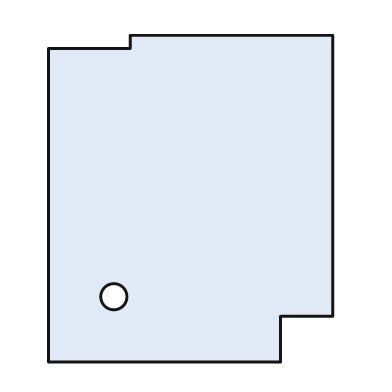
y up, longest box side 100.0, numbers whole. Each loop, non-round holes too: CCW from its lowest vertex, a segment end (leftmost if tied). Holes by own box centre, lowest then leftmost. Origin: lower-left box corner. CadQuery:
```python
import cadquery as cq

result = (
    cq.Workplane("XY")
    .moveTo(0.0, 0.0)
    .lineTo(71.0, 0.0)
    .lineTo(71.0, 14.0)
    .lineTo(87.0, 14.0)
    .lineTo(87.0, 100.0)
    .lineTo(25.0, 100.0)
    .lineTo(25.0, 96.0)
    .lineTo(0.0, 96.0)
    .close()
    .moveTo(20.0, 20.0)
    .circle(4.0)
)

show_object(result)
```